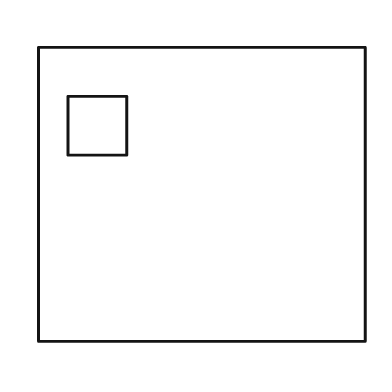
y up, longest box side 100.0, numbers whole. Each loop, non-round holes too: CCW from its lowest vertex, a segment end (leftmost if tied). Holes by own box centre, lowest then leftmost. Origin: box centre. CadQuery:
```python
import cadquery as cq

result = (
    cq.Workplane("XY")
    .moveTo(-50.0, -45.0)
    .lineTo(50.0, -45.0)
    .lineTo(50.0, 45.0)
    .lineTo(-50.0, 45.0)
    .close()
    .moveTo(-41.0, 12.0)
    .lineTo(-23.0, 12.0)
    .lineTo(-23.0, 30.0)
    .lineTo(-41.0, 30.0)
    .close()
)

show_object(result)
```